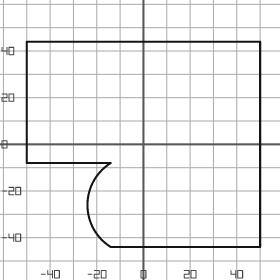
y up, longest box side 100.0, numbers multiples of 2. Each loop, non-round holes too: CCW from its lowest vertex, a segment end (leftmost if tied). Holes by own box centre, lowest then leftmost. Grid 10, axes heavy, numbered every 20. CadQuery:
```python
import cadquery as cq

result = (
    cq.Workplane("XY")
    .moveTo(-14.0, -44.0)
    .lineTo(50.0, -44.0)
    .lineTo(50.0, 44.0)
    .lineTo(-50.0, 44.0)
    .lineTo(-50.0, -8.0)
    .lineTo(-14.0, -8.0)
    .threePointArc((-24.0, -26.0), (-14.0, -44.0))
    .close()
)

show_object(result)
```